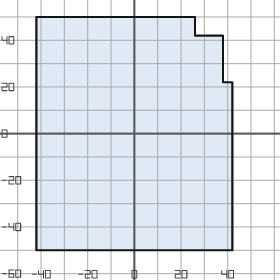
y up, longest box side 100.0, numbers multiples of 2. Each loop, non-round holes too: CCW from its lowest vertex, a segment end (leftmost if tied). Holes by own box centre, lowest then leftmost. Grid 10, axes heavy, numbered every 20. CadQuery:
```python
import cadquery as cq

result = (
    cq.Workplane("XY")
    .moveTo(-42.0, -50.0)
    .lineTo(42.0, -50.0)
    .lineTo(42.0, 22.0)
    .lineTo(38.0, 22.0)
    .lineTo(38.0, 42.0)
    .lineTo(26.0, 42.0)
    .lineTo(26.0, 50.0)
    .lineTo(-42.0, 50.0)
    .close()
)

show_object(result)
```